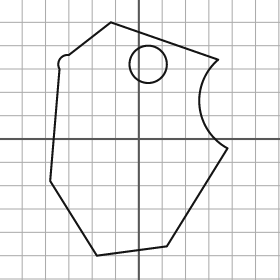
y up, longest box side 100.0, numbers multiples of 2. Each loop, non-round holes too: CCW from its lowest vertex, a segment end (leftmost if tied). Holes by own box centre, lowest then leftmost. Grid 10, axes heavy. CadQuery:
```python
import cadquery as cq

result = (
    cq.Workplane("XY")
    .moveTo(-18.0, -50.0)
    .lineTo(12.0, -46.0)
    .lineTo(38.0, -4.0)
    .threePointArc((26.0, 14.0), (34.0, 34.0))
    .lineTo(-12.0, 50.0)
    .lineTo(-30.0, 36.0)
    .threePointArc((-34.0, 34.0), (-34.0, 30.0))
    .lineTo(-38.0, -18.0)
    .close()
    .moveTo(4.0, 32.0)
    .circle(8.0)
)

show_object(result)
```